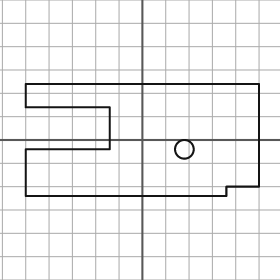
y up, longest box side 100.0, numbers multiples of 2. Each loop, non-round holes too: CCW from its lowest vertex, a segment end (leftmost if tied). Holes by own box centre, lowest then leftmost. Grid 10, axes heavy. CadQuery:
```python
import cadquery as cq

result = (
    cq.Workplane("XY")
    .moveTo(-50.0, -24.0)
    .lineTo(36.0, -24.0)
    .lineTo(36.0, -20.0)
    .lineTo(50.0, -20.0)
    .lineTo(50.0, 24.0)
    .lineTo(-50.0, 24.0)
    .lineTo(-50.0, 14.0)
    .lineTo(-14.0, 14.0)
    .lineTo(-14.0, -4.0)
    .lineTo(-50.0, -4.0)
    .close()
    .moveTo(18.0, -4.0)
    .circle(4.0)
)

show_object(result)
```